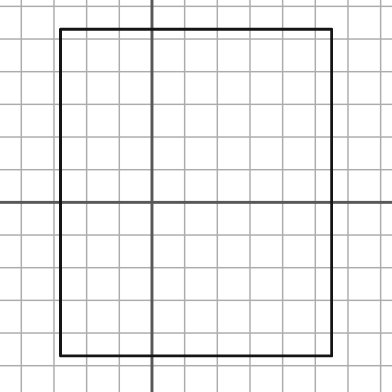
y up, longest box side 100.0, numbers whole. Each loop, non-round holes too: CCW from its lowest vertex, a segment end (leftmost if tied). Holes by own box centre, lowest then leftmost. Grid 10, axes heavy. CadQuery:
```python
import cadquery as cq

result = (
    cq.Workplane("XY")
    .moveTo(-28.0, -47.0)
    .lineTo(55.0, -47.0)
    .lineTo(55.0, 53.0)
    .lineTo(-28.0, 53.0)
    .close()
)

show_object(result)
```